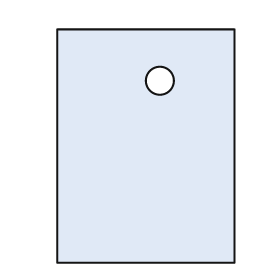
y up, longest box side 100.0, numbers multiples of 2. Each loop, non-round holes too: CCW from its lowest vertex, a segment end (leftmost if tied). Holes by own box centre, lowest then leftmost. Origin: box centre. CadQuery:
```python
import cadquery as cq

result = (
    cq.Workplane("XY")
    .moveTo(-38.0, -50.0)
    .lineTo(38.0, -50.0)
    .lineTo(38.0, 50.0)
    .lineTo(-38.0, 50.0)
    .close()
    .moveTo(6.0, 28.0)
    .circle(6.0)
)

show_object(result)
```